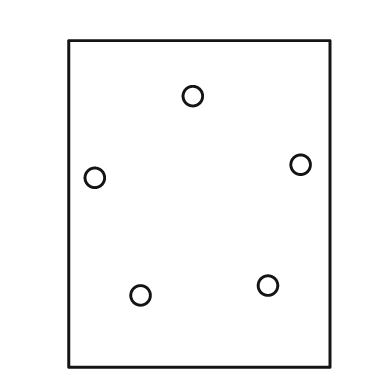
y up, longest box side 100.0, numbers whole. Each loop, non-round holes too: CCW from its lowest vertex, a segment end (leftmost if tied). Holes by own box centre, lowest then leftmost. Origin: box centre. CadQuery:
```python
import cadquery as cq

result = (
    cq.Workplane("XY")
    .moveTo(-40.0, -50.0)
    .lineTo(40.0, -50.0)
    .lineTo(40.0, 50.0)
    .lineTo(-40.0, 50.0)
    .close()
    .moveTo(-18.0, -28.0)
    .circle(3.0)
    .moveTo(21.0, -25.0)
    .circle(3.0)
    .moveTo(-32.0, 8.0)
    .circle(3.0)
    .moveTo(31.0, 12.0)
    .circle(3.0)
    .moveTo(-2.0, 33.0)
    .circle(3.0)
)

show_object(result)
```